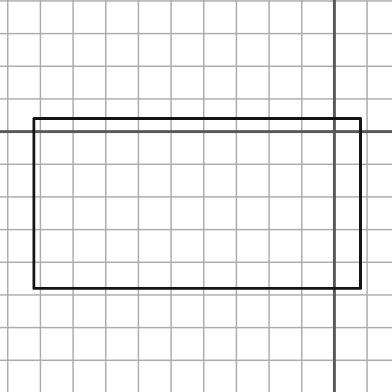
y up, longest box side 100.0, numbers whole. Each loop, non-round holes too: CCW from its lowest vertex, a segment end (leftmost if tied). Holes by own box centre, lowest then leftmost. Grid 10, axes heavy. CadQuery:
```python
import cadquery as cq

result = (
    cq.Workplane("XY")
    .moveTo(-92.0, -48.0)
    .lineTo(8.0, -48.0)
    .lineTo(8.0, 4.0)
    .lineTo(-92.0, 4.0)
    .close()
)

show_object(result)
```